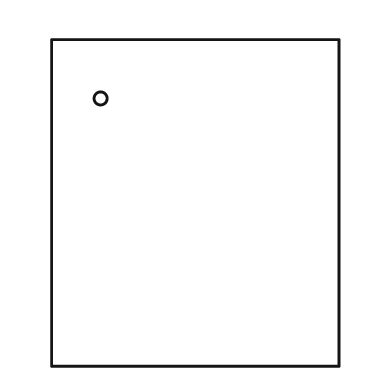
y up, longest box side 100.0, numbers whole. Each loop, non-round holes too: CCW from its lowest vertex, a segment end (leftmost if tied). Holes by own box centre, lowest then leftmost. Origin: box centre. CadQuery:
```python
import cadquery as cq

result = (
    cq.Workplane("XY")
    .moveTo(-44.0, -50.0)
    .lineTo(44.0, -50.0)
    .lineTo(44.0, 50.0)
    .lineTo(-44.0, 50.0)
    .close()
    .moveTo(-29.0, 32.0)
    .circle(2.0)
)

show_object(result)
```